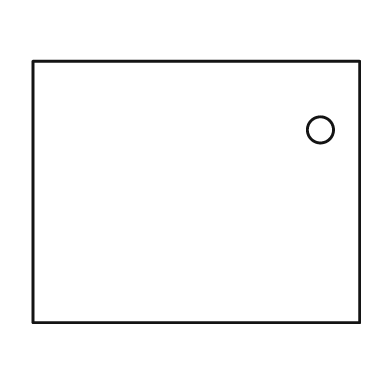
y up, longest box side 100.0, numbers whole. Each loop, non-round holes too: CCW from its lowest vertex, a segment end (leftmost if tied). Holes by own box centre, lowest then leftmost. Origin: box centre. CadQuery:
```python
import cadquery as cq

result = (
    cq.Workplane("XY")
    .moveTo(-50.0, -40.0)
    .lineTo(50.0, -40.0)
    .lineTo(50.0, 40.0)
    .lineTo(-50.0, 40.0)
    .close()
    .moveTo(38.0, 19.0)
    .circle(4.0)
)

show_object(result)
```